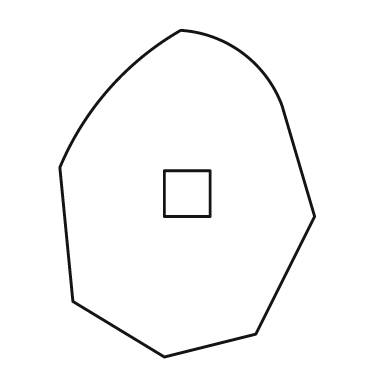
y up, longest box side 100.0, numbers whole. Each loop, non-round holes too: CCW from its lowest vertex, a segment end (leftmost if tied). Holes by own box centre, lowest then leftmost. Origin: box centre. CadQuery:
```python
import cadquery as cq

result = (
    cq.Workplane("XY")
    .moveTo(-7.0, -50.0)
    .lineTo(21.0, -43.0)
    .lineTo(39.0, -7.0)
    .lineTo(29.0, 27.0)
    .threePointArc((17.0, 43.0), (-2.0, 50.0))
    .threePointArc((-24.0, 32.0), (-39.0, 8.0))
    .lineTo(-35.0, -33.0)
    .close()
    .moveTo(-7.0, -7.0)
    .lineTo(7.0, -7.0)
    .lineTo(7.0, 7.0)
    .lineTo(-7.0, 7.0)
    .close()
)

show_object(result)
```